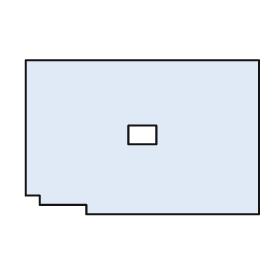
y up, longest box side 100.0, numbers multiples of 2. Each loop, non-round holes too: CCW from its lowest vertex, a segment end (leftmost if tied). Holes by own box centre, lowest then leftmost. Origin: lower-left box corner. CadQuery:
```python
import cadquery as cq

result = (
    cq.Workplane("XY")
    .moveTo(26.0, 0.0)
    .lineTo(100.0, 0.0)
    .lineTo(100.0, 66.0)
    .lineTo(0.0, 66.0)
    .lineTo(0.0, 8.0)
    .lineTo(6.0, 8.0)
    .lineTo(6.0, 4.0)
    .lineTo(26.0, 4.0)
    .close()
    .moveTo(44.0, 30.0)
    .lineTo(56.0, 30.0)
    .lineTo(56.0, 38.0)
    .lineTo(44.0, 38.0)
    .close()
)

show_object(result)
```